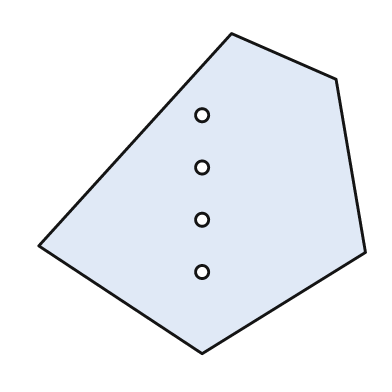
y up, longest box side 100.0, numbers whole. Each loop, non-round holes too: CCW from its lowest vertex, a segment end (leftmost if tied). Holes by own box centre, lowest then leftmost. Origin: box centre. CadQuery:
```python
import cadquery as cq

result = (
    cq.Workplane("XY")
    .moveTo(0.0, -49.0)
    .lineTo(50.0, -18.0)
    .lineTo(41.0, 35.0)
    .lineTo(9.0, 49.0)
    .lineTo(-50.0, -16.0)
    .close()
    .moveTo(0.0, -24.0)
    .circle(2.0)
    .moveTo(0.0, -8.0)
    .circle(2.0)
    .moveTo(0.0, 8.0)
    .circle(2.0)
    .moveTo(0.0, 24.0)
    .circle(2.0)
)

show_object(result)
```